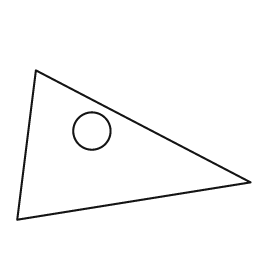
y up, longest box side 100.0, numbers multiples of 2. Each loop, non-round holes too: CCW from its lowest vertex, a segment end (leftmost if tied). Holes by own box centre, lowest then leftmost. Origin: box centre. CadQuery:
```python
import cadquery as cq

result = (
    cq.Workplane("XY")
    .moveTo(-50.0, -32.0)
    .lineTo(50.0, -16.0)
    .lineTo(-42.0, 32.0)
    .close()
    .moveTo(-18.0, 6.0)
    .circle(8.0)
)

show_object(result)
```